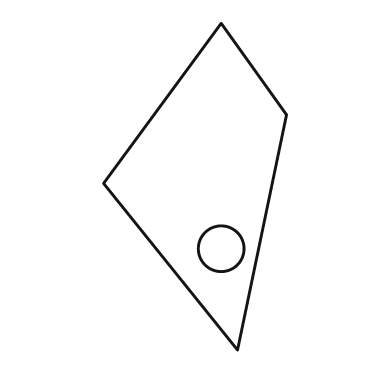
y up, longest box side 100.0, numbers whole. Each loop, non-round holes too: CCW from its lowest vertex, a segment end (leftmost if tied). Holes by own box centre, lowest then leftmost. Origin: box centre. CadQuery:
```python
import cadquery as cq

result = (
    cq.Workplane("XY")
    .moveTo(13.0, -50.0)
    .lineTo(28.0, 22.0)
    .lineTo(8.0, 50.0)
    .lineTo(-28.0, 1.0)
    .close()
    .moveTo(8.0, -19.0)
    .circle(7.0)
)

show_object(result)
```